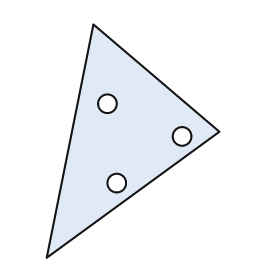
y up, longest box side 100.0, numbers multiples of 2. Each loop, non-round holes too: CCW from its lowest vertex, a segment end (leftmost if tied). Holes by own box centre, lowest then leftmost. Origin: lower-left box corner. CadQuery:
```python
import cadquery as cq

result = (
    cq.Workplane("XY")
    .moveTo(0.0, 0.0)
    .lineTo(74.0, 54.0)
    .lineTo(20.0, 100.0)
    .close()
    .moveTo(30.0, 32.0)
    .circle(4.0)
    .moveTo(58.0, 52.0)
    .circle(4.0)
    .moveTo(26.0, 66.0)
    .circle(4.0)
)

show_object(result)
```